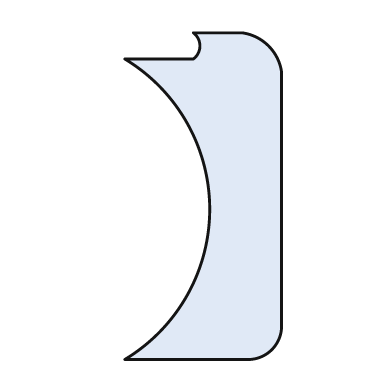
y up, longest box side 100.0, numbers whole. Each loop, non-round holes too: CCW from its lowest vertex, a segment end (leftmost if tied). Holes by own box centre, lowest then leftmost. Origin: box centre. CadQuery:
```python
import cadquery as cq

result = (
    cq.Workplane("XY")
    .moveTo(-24.0, -50.0)
    .lineTo(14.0, -50.0)
    .threePointArc((21.0, -47.0), (24.0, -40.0))
    .lineTo(24.0, 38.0)
    .threePointArc((20.0, 46.0), (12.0, 50.0))
    .lineTo(-3.0, 50.0)
    .threePointArc((-1.0, 46.0), (-3.0, 42.0))
    .lineTo(-24.0, 42.0)
    .threePointArc((2.0, -4.0), (-24.0, -50.0))
    .close()
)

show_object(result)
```